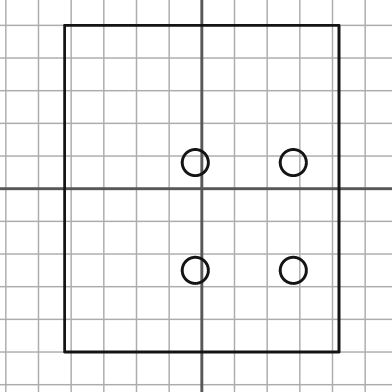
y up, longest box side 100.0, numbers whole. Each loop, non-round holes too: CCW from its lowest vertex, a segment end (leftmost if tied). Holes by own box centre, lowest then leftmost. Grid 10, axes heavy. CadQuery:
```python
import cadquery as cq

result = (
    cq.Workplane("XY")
    .moveTo(-42.0, -50.0)
    .lineTo(42.0, -50.0)
    .lineTo(42.0, 50.0)
    .lineTo(-42.0, 50.0)
    .close()
    .moveTo(-2.0, -25.0)
    .circle(4.0)
    .moveTo(28.0, -25.0)
    .circle(4.0)
    .moveTo(-2.0, 8.0)
    .circle(4.0)
    .moveTo(28.0, 8.0)
    .circle(4.0)
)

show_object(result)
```